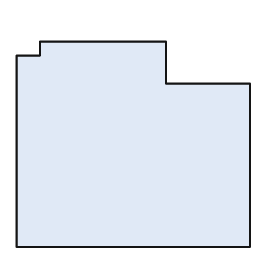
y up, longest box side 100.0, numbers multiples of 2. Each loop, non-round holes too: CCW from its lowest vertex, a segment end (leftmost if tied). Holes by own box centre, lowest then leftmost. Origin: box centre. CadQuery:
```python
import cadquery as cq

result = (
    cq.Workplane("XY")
    .moveTo(-50.0, -44.0)
    .lineTo(50.0, -44.0)
    .lineTo(50.0, 26.0)
    .lineTo(14.0, 26.0)
    .lineTo(14.0, 44.0)
    .lineTo(-40.0, 44.0)
    .lineTo(-40.0, 38.0)
    .lineTo(-50.0, 38.0)
    .close()
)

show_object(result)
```